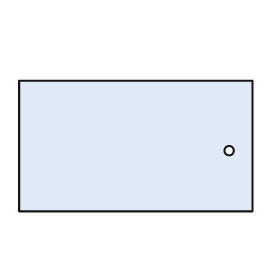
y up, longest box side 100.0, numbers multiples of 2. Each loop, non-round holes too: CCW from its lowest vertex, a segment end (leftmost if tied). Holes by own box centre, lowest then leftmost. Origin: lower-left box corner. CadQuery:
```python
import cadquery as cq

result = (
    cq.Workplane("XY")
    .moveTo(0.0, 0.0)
    .lineTo(100.0, 0.0)
    .lineTo(100.0, 56.0)
    .lineTo(0.0, 56.0)
    .close()
    .moveTo(90.0, 26.0)
    .circle(2.0)
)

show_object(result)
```